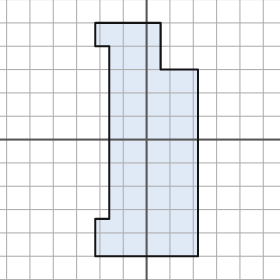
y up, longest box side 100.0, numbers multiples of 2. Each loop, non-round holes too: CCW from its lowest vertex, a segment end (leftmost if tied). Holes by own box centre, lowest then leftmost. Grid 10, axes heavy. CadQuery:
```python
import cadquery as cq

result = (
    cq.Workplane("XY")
    .moveTo(-22.0, -50.0)
    .lineTo(22.0, -50.0)
    .lineTo(22.0, 30.0)
    .lineTo(6.0, 30.0)
    .lineTo(6.0, 50.0)
    .lineTo(-22.0, 50.0)
    .lineTo(-22.0, 40.0)
    .lineTo(-16.0, 40.0)
    .lineTo(-16.0, -34.0)
    .lineTo(-22.0, -34.0)
    .close()
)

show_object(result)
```